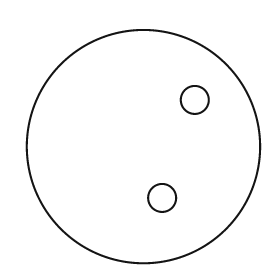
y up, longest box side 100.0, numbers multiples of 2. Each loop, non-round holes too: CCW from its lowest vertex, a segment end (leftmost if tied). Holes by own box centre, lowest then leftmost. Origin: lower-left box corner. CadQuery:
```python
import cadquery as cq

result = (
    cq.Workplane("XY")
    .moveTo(50.0, 50.0)
    .circle(50.0)
    .moveTo(58.0, 28.0)
    .circle(6.0)
    .moveTo(72.0, 70.0)
    .circle(6.0)
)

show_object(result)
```